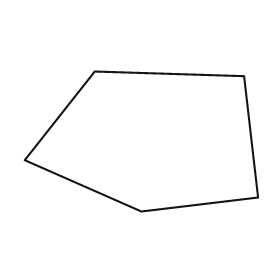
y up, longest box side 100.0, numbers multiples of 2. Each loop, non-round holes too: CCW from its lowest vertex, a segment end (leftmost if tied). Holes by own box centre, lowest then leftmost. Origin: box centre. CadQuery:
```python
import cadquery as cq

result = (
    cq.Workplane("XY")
    .moveTo(0.0, -30.0)
    .lineTo(50.0, -24.0)
    .lineTo(44.0, 28.0)
    .lineTo(-20.0, 30.0)
    .lineTo(-50.0, -8.0)
    .close()
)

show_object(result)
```